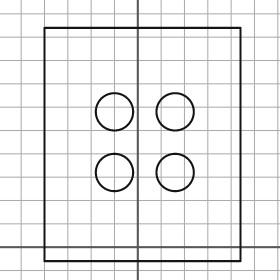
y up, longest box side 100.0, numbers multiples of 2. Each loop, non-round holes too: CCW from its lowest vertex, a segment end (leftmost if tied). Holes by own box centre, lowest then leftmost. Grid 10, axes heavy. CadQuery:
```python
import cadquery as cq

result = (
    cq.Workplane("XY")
    .moveTo(-40.0, -6.0)
    .lineTo(44.0, -6.0)
    .lineTo(44.0, 94.0)
    .lineTo(-40.0, 94.0)
    .close()
    .moveTo(-10.0, 32.0)
    .circle(8.0)
    .moveTo(16.0, 32.0)
    .circle(8.0)
    .moveTo(-10.0, 58.0)
    .circle(8.0)
    .moveTo(16.0, 58.0)
    .circle(8.0)
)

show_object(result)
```